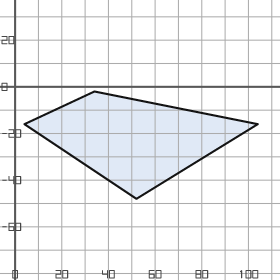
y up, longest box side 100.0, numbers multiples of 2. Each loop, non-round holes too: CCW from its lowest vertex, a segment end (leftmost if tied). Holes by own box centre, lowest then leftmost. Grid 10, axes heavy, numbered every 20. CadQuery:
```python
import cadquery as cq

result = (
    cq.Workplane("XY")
    .moveTo(52.0, -48.0)
    .lineTo(104.0, -16.0)
    .lineTo(34.0, -2.0)
    .lineTo(4.0, -16.0)
    .close()
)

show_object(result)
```